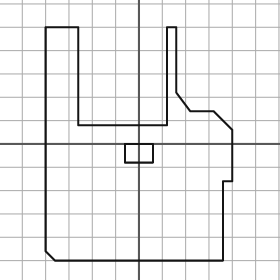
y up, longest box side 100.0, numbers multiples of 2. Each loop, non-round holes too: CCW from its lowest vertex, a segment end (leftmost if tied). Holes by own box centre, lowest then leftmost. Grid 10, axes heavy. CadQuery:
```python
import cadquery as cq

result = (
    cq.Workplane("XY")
    .moveTo(-36.0, -50.0)
    .lineTo(36.0, -50.0)
    .lineTo(36.0, -16.0)
    .lineTo(40.0, -16.0)
    .lineTo(40.0, 6.0)
    .lineTo(32.0, 14.0)
    .lineTo(22.0, 14.0)
    .lineTo(16.0, 22.0)
    .lineTo(16.0, 50.0)
    .lineTo(12.0, 50.0)
    .lineTo(12.0, 8.0)
    .lineTo(-26.0, 8.0)
    .lineTo(-26.0, 50.0)
    .lineTo(-40.0, 50.0)
    .lineTo(-40.0, -46.0)
    .close()
    .moveTo(-6.0, -8.0)
    .lineTo(6.0, -8.0)
    .lineTo(6.0, 0.0)
    .lineTo(-6.0, 0.0)
    .close()
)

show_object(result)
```